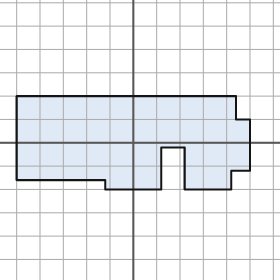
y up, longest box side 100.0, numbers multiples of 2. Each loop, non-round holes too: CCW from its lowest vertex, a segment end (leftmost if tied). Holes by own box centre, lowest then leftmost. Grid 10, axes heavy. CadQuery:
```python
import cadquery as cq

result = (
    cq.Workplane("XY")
    .moveTo(-12.0, -20.0)
    .lineTo(12.0, -20.0)
    .lineTo(12.0, -2.0)
    .lineTo(22.0, -2.0)
    .lineTo(22.0, -20.0)
    .lineTo(42.0, -20.0)
    .lineTo(42.0, -12.0)
    .lineTo(50.0, -12.0)
    .lineTo(50.0, 10.0)
    .lineTo(44.0, 10.0)
    .lineTo(44.0, 20.0)
    .lineTo(-50.0, 20.0)
    .lineTo(-50.0, -16.0)
    .lineTo(-12.0, -16.0)
    .close()
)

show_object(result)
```